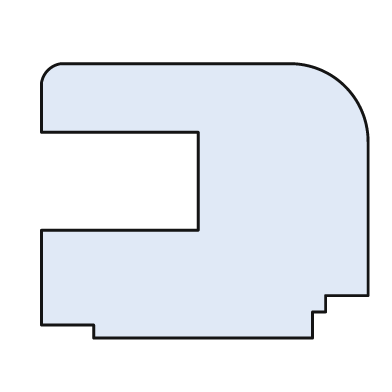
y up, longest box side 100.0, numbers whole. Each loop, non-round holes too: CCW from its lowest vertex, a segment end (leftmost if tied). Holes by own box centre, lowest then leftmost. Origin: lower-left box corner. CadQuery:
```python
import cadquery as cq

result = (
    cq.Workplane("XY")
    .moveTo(16.0, 0.0)
    .lineTo(83.0, 0.0)
    .lineTo(83.0, 8.0)
    .lineTo(87.0, 8.0)
    .lineTo(87.0, 13.0)
    .lineTo(100.0, 13.0)
    .lineTo(100.0, 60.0)
    .threePointArc((93.0, 77.0), (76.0, 84.0))
    .lineTo(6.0, 84.0)
    .threePointArc((2.0, 82.0), (0.0, 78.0))
    .lineTo(0.0, 63.0)
    .lineTo(48.0, 63.0)
    .lineTo(48.0, 33.0)
    .lineTo(0.0, 33.0)
    .lineTo(0.0, 4.0)
    .lineTo(16.0, 4.0)
    .close()
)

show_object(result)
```